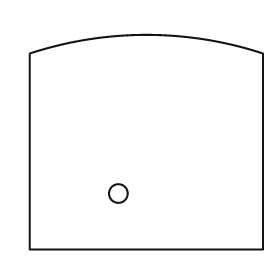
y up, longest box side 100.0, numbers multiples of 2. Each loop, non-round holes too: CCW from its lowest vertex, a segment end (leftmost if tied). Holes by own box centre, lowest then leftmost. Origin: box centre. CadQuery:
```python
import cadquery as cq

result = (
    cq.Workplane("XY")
    .moveTo(-50.0, -46.0)
    .lineTo(50.0, -46.0)
    .lineTo(50.0, 38.0)
    .threePointArc((0.0, 46.0), (-50.0, 38.0))
    .close()
    .moveTo(-12.0, -22.0)
    .circle(4.0)
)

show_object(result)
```